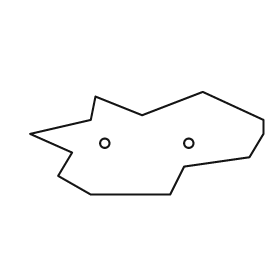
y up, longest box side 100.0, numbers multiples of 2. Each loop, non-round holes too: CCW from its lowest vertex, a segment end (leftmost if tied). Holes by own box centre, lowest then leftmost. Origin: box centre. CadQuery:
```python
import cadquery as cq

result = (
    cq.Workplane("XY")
    .moveTo(-24.0, -22.0)
    .lineTo(10.0, -22.0)
    .lineTo(16.0, -10.0)
    .lineTo(44.0, -6.0)
    .lineTo(50.0, 4.0)
    .lineTo(50.0, 10.0)
    .lineTo(24.0, 22.0)
    .lineTo(-2.0, 12.0)
    .lineTo(-22.0, 20.0)
    .lineTo(-24.0, 10.0)
    .lineTo(-50.0, 4.0)
    .lineTo(-32.0, -4.0)
    .lineTo(-38.0, -14.0)
    .close()
    .moveTo(-18.0, 0.0)
    .circle(2.0)
    .moveTo(18.0, 0.0)
    .circle(2.0)
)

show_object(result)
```